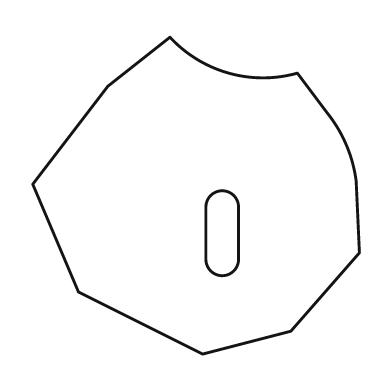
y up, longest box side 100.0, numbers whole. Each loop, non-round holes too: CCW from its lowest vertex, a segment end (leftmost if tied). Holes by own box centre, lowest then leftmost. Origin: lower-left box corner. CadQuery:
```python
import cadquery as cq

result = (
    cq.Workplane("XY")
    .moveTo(52.0, 0.0)
    .lineTo(79.0, 7.0)
    .lineTo(100.0, 31.0)
    .lineTo(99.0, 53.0)
    .threePointArc((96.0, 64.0), (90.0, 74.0))
    .lineTo(81.0, 86.0)
    .threePointArc((60.0, 86.0), (42.0, 97.0))
    .lineTo(23.0, 82.0)
    .lineTo(0.0, 52.0)
    .lineTo(14.0, 19.0)
    .close()
    .moveTo(53.0, 29.0)
    .threePointArc((58.0, 24.0), (63.0, 29.0))
    .lineTo(63.0, 45.0)
    .threePointArc((58.0, 50.0), (53.0, 45.0))
    .close()
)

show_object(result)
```